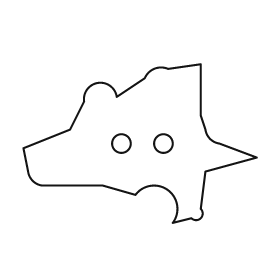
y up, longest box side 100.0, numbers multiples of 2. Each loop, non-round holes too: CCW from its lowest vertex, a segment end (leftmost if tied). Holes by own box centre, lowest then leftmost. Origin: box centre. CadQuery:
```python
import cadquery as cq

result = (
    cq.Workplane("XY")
    .moveTo(14.0, -34.0)
    .lineTo(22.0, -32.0)
    .threePointArc((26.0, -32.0), (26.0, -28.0))
    .lineTo(28.0, -12.0)
    .lineTo(50.0, -6.0)
    .lineTo(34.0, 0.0)
    .threePointArc((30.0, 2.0), (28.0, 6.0))
    .lineTo(26.0, 12.0)
    .lineTo(26.0, 34.0)
    .lineTo(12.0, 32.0)
    .threePointArc((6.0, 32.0), (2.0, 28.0))
    .lineTo(-10.0, 20.0)
    .threePointArc((-18.0, 26.0), (-24.0, 18.0))
    .lineTo(-30.0, 6.0)
    .lineTo(-50.0, -2.0)
    .lineTo(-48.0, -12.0)
    .threePointArc((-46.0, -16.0), (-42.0, -18.0))
    .lineTo(-16.0, -18.0)
    .lineTo(-2.0, -22.0)
    .threePointArc((12.0, -20.0), (14.0, -34.0))
    .close()
    .moveTo(-8.0, 0.0)
    .circle(4.0)
    .moveTo(10.0, 0.0)
    .circle(4.0)
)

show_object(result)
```